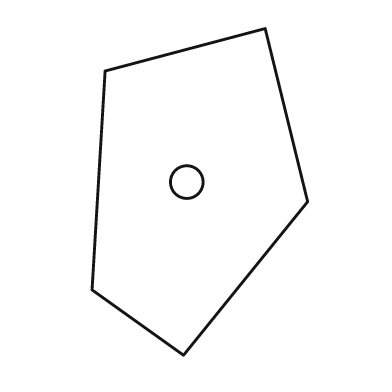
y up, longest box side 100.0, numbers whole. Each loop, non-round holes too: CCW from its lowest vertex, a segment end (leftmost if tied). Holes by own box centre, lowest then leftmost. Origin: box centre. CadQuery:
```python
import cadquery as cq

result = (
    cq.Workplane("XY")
    .moveTo(-5.0, -50.0)
    .lineTo(33.0, -3.0)
    .lineTo(20.0, 50.0)
    .lineTo(-29.0, 37.0)
    .lineTo(-33.0, -30.0)
    .close()
    .moveTo(-4.0, 3.0)
    .circle(5.0)
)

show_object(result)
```